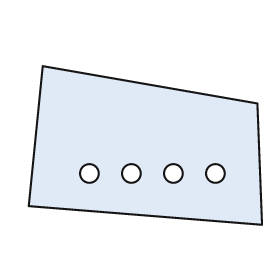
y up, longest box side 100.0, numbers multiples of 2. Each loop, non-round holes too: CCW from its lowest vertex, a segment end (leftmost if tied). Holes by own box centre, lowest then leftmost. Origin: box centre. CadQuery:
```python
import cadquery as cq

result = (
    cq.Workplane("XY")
    .moveTo(50.0, -34.0)
    .lineTo(48.0, 18.0)
    .lineTo(-44.0, 34.0)
    .lineTo(-50.0, -26.0)
    .close()
    .moveTo(-24.0, -12.0)
    .circle(4.0)
    .moveTo(-6.0, -12.0)
    .circle(4.0)
    .moveTo(12.0, -12.0)
    .circle(4.0)
    .moveTo(30.0, -12.0)
    .circle(4.0)
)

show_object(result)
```